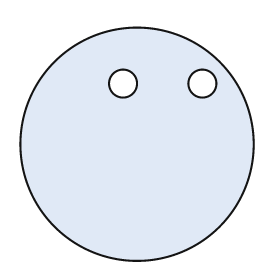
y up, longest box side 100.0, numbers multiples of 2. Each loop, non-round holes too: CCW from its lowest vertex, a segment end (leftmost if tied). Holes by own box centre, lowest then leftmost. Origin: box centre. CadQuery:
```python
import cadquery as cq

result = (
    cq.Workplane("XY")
    .moveTo(0.0, 0.0)
    .circle(50.0)
    .moveTo(-6.0, 26.0)
    .circle(6.0)
    .moveTo(28.0, 26.0)
    .circle(6.0)
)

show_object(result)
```